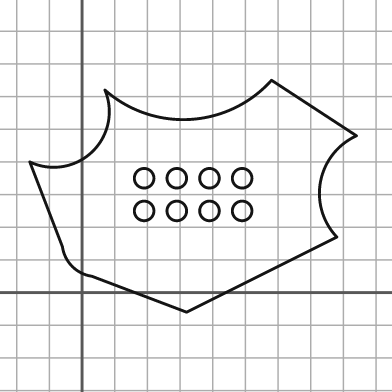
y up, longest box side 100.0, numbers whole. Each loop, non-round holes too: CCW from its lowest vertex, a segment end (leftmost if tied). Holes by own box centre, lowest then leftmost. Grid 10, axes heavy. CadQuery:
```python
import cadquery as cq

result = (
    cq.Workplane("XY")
    .moveTo(32.0, -6.0)
    .lineTo(78.0, 17.0)
    .threePointArc((73.0, 34.0), (84.0, 48.0))
    .lineTo(58.0, 65.0)
    .threePointArc((33.0, 53.0), (7.0, 62.0))
    .threePointArc((3.0, 43.0), (-16.0, 40.0))
    .lineTo(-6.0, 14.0)
    .threePointArc((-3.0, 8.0), (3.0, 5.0))
    .close()
    .moveTo(19.0, 25.0)
    .circle(3.0)
    .moveTo(29.0, 25.0)
    .circle(3.0)
    .moveTo(39.0, 25.0)
    .circle(3.0)
    .moveTo(49.0, 25.0)
    .circle(3.0)
    .moveTo(19.0, 35.0)
    .circle(3.0)
    .moveTo(29.0, 35.0)
    .circle(3.0)
    .moveTo(39.0, 35.0)
    .circle(3.0)
    .moveTo(49.0, 35.0)
    .circle(3.0)
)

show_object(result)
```